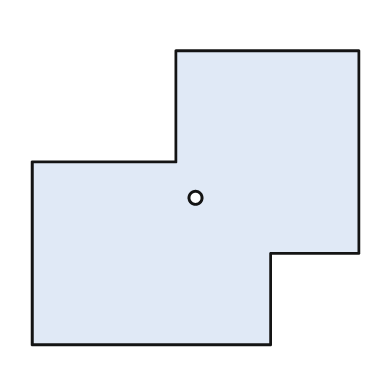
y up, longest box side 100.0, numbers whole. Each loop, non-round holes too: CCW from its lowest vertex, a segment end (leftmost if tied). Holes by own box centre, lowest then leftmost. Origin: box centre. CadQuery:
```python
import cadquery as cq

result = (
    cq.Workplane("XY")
    .moveTo(-50.0, -45.0)
    .lineTo(23.0, -45.0)
    .lineTo(23.0, -17.0)
    .lineTo(50.0, -17.0)
    .lineTo(50.0, 45.0)
    .lineTo(-6.0, 45.0)
    .lineTo(-6.0, 11.0)
    .lineTo(-50.0, 11.0)
    .close()
    .moveTo(0.0, 0.0)
    .circle(2.0)
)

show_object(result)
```